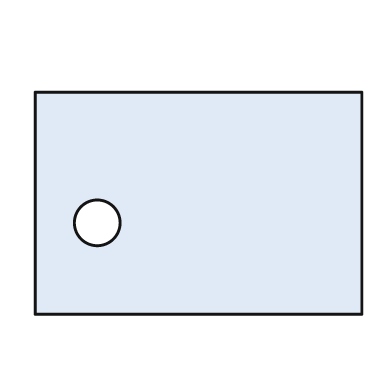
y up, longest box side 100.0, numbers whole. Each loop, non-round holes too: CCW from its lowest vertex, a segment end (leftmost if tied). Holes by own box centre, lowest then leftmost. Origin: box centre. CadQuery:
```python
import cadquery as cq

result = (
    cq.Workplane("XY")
    .moveTo(-50.0, -34.0)
    .lineTo(50.0, -34.0)
    .lineTo(50.0, 34.0)
    .lineTo(-50.0, 34.0)
    .close()
    .moveTo(-31.0, -6.0)
    .circle(7.0)
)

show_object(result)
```